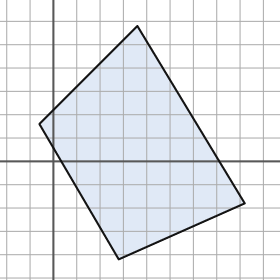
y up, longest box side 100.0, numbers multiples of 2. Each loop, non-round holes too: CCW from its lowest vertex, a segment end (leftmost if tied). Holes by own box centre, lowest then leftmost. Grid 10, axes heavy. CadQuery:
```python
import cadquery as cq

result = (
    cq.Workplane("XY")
    .moveTo(28.0, -42.0)
    .lineTo(82.0, -18.0)
    .lineTo(36.0, 58.0)
    .lineTo(-6.0, 16.0)
    .close()
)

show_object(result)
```